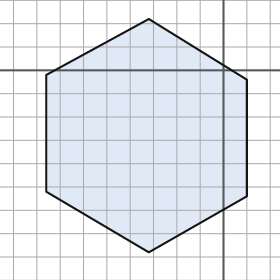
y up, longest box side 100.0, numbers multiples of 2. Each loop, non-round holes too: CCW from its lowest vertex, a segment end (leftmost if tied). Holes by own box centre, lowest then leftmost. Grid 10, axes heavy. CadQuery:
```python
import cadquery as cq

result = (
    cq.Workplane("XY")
    .moveTo(-32.0, -78.0)
    .lineTo(10.0, -54.0)
    .lineTo(10.0, -4.0)
    .lineTo(-32.0, 22.0)
    .lineTo(-76.0, -2.0)
    .lineTo(-76.0, -52.0)
    .close()
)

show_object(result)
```